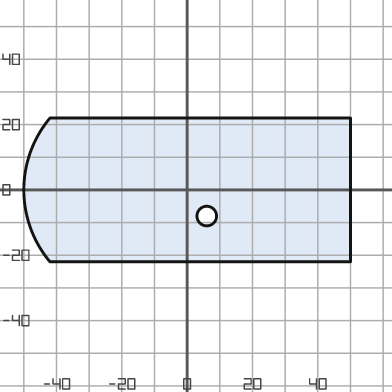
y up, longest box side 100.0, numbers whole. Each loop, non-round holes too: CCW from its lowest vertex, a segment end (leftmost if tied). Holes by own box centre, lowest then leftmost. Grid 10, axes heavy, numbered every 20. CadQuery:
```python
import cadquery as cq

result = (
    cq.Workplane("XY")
    .moveTo(-42.0, -22.0)
    .lineTo(50.0, -22.0)
    .lineTo(50.0, 22.0)
    .lineTo(-42.0, 22.0)
    .threePointArc((-50.0, 0.0), (-42.0, -22.0))
    .close()
    .moveTo(6.0, -8.0)
    .circle(3.0)
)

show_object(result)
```